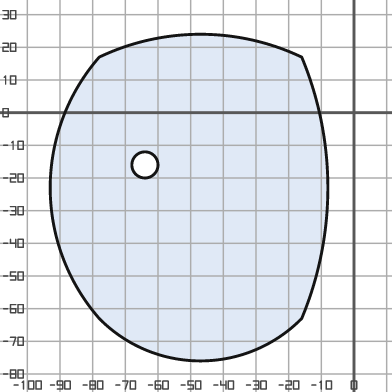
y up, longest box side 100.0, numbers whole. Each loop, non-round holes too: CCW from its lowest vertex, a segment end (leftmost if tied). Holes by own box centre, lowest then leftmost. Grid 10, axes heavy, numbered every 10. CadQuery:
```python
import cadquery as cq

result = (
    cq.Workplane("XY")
    .moveTo(-78.0, -63.0)
    .threePointArc((-47.0, -76.0), (-16.0, -63.0))
    .threePointArc((-8.0, -23.0), (-16.0, 17.0))
    .threePointArc((-47.0, 24.0), (-78.0, 17.0))
    .threePointArc((-93.0, -23.0), (-78.0, -63.0))
    .close()
    .moveTo(-64.0, -16.0)
    .circle(4.0)
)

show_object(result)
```